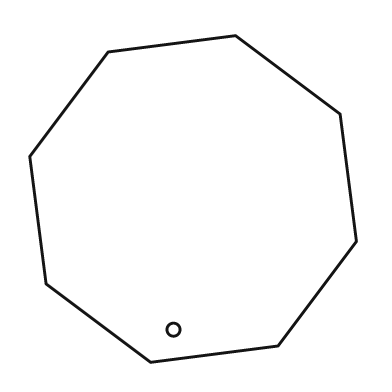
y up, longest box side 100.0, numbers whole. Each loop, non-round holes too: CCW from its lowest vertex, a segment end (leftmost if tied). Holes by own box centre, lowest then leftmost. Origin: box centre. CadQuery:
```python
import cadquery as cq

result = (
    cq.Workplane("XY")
    .moveTo(-13.0, -50.0)
    .lineTo(26.0, -45.0)
    .lineTo(50.0, -13.0)
    .lineTo(45.0, 26.0)
    .lineTo(13.0, 50.0)
    .lineTo(-26.0, 45.0)
    .lineTo(-50.0, 13.0)
    .lineTo(-45.0, -26.0)
    .close()
    .moveTo(-6.0, -40.0)
    .circle(2.0)
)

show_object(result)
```